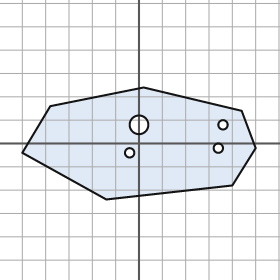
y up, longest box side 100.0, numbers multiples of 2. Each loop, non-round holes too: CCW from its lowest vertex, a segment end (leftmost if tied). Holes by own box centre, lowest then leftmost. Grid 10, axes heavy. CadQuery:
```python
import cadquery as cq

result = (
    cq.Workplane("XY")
    .moveTo(-14.0, -24.0)
    .lineTo(40.0, -18.0)
    .lineTo(50.0, -2.0)
    .lineTo(44.0, 14.0)
    .lineTo(2.0, 24.0)
    .lineTo(-38.0, 16.0)
    .lineTo(-50.0, -4.0)
    .close()
    .moveTo(-4.0, -4.0)
    .circle(2.0)
    .moveTo(34.0, -2.0)
    .circle(2.0)
    .moveTo(0.0, 8.0)
    .circle(4.0)
    .moveTo(36.0, 8.0)
    .circle(2.0)
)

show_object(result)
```